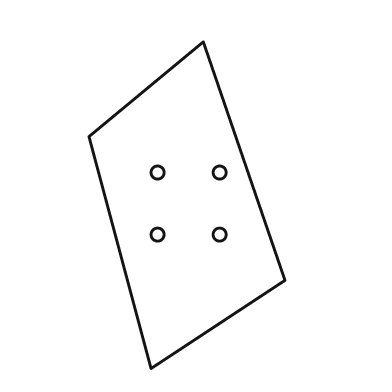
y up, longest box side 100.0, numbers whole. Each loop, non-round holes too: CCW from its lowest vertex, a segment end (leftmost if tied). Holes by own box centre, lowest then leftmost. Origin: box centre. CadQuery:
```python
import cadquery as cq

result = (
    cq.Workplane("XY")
    .moveTo(-11.0, -50.0)
    .lineTo(30.0, -23.0)
    .lineTo(5.0, 50.0)
    .lineTo(-30.0, 21.0)
    .close()
    .moveTo(-9.0, -9.0)
    .circle(2.0)
    .moveTo(10.0, -9.0)
    .circle(2.0)
    .moveTo(-9.0, 10.0)
    .circle(2.0)
    .moveTo(10.0, 10.0)
    .circle(2.0)
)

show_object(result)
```